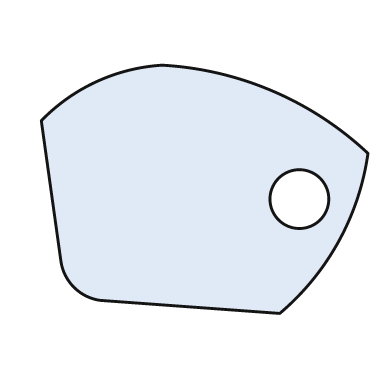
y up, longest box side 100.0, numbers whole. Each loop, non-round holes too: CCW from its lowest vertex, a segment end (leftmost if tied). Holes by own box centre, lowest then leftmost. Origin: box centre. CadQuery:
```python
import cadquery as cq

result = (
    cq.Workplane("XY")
    .moveTo(23.0, -38.0)
    .threePointArc((41.0, -16.0), (50.0, 11.0))
    .threePointArc((21.0, 30.0), (-13.0, 38.0))
    .threePointArc((-33.0, 33.0), (-50.0, 21.0))
    .lineTo(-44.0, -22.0)
    .threePointArc((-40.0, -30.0), (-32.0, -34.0))
    .close()
    .moveTo(29.0, -3.0)
    .circle(9.0)
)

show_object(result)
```